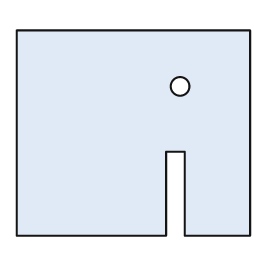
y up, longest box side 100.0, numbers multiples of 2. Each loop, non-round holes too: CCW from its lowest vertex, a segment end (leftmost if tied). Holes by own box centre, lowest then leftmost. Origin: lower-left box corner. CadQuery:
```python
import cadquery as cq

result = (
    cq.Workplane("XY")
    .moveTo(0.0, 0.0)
    .lineTo(64.0, 0.0)
    .lineTo(64.0, 36.0)
    .lineTo(72.0, 36.0)
    .lineTo(72.0, 0.0)
    .lineTo(100.0, 0.0)
    .lineTo(100.0, 88.0)
    .lineTo(0.0, 88.0)
    .close()
    .moveTo(70.0, 64.0)
    .circle(4.0)
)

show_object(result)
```